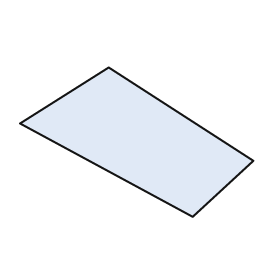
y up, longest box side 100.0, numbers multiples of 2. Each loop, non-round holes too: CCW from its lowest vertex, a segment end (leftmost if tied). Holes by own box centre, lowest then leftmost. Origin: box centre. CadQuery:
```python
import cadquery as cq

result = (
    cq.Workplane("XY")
    .moveTo(24.0, -32.0)
    .lineTo(50.0, -8.0)
    .lineTo(-12.0, 32.0)
    .lineTo(-50.0, 8.0)
    .close()
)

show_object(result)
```